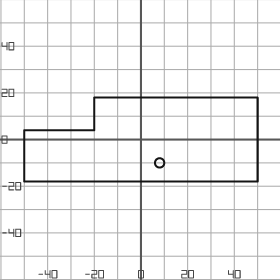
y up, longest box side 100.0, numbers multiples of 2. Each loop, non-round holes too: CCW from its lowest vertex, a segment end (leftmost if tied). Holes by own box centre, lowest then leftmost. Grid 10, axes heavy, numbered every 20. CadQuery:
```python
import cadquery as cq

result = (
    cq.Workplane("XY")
    .moveTo(-50.0, -18.0)
    .lineTo(50.0, -18.0)
    .lineTo(50.0, 18.0)
    .lineTo(-20.0, 18.0)
    .lineTo(-20.0, 4.0)
    .lineTo(-50.0, 4.0)
    .close()
    .moveTo(8.0, -10.0)
    .circle(2.0)
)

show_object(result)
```